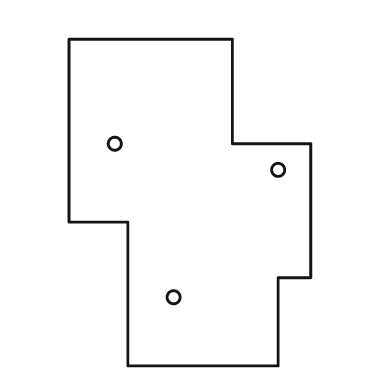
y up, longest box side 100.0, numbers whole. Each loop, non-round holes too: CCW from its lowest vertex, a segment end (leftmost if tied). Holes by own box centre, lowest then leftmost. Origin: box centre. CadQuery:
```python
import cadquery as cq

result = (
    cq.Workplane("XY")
    .moveTo(-19.0, -50.0)
    .lineTo(27.0, -50.0)
    .lineTo(27.0, -23.0)
    .lineTo(37.0, -23.0)
    .lineTo(37.0, 18.0)
    .lineTo(13.0, 18.0)
    .lineTo(13.0, 50.0)
    .lineTo(-37.0, 50.0)
    .lineTo(-37.0, -6.0)
    .lineTo(-19.0, -6.0)
    .close()
    .moveTo(-5.0, -29.0)
    .circle(2.0)
    .moveTo(27.0, 10.0)
    .circle(2.0)
    .moveTo(-23.0, 18.0)
    .circle(2.0)
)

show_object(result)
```